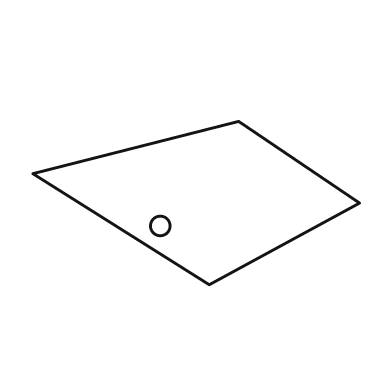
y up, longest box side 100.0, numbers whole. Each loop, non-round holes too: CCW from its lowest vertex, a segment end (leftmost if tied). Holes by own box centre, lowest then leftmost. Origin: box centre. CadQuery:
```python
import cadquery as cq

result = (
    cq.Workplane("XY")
    .moveTo(4.0, -25.0)
    .lineTo(50.0, 0.0)
    .lineTo(13.0, 25.0)
    .lineTo(-50.0, 9.0)
    .close()
    .moveTo(-11.0, -7.0)
    .circle(3.0)
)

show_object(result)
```